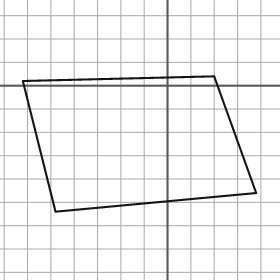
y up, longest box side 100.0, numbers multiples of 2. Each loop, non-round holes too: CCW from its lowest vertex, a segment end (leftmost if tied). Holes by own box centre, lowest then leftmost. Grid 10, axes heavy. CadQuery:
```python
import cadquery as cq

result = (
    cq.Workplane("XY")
    .moveTo(-48.0, -54.0)
    .lineTo(38.0, -46.0)
    .lineTo(20.0, 4.0)
    .lineTo(-62.0, 2.0)
    .close()
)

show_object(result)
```